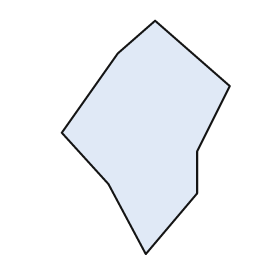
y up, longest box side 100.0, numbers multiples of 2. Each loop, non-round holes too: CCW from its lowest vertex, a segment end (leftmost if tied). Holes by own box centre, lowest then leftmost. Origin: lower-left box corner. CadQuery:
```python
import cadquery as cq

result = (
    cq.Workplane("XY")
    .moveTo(36.0, 0.0)
    .lineTo(58.0, 26.0)
    .lineTo(58.0, 44.0)
    .lineTo(72.0, 72.0)
    .lineTo(40.0, 100.0)
    .lineTo(24.0, 86.0)
    .lineTo(0.0, 52.0)
    .lineTo(20.0, 30.0)
    .close()
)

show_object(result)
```